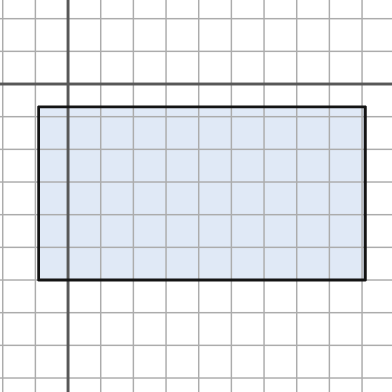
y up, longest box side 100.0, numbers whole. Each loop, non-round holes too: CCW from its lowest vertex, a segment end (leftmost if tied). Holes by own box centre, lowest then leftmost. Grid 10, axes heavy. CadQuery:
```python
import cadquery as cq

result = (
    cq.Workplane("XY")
    .moveTo(-9.0, -60.0)
    .lineTo(91.0, -60.0)
    .lineTo(91.0, -7.0)
    .lineTo(-9.0, -7.0)
    .close()
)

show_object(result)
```